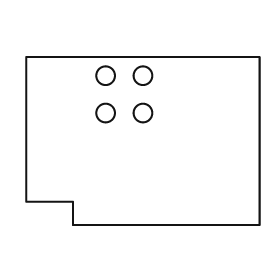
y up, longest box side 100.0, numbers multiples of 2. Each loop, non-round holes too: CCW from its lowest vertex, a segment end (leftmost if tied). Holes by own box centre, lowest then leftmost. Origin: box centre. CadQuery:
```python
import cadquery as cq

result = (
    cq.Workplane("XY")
    .moveTo(-30.0, -36.0)
    .lineTo(50.0, -36.0)
    .lineTo(50.0, 36.0)
    .lineTo(-50.0, 36.0)
    .lineTo(-50.0, -26.0)
    .lineTo(-30.0, -26.0)
    .close()
    .moveTo(-16.0, 12.0)
    .circle(4.0)
    .moveTo(0.0, 12.0)
    .circle(4.0)
    .moveTo(-16.0, 28.0)
    .circle(4.0)
    .moveTo(0.0, 28.0)
    .circle(4.0)
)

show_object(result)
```